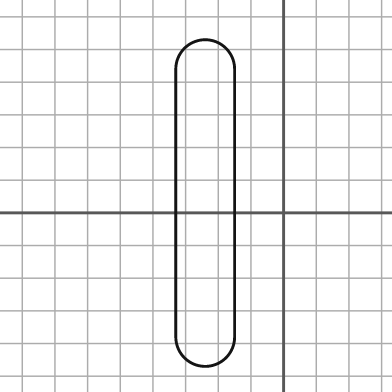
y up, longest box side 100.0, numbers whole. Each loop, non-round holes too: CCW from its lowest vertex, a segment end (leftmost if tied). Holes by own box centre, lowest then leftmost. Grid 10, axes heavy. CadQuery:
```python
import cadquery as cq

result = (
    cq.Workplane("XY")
    .moveTo(-33.0, -38.0)
    .threePointArc((-24.0, -47.0), (-15.0, -38.0))
    .lineTo(-15.0, 44.0)
    .threePointArc((-24.0, 53.0), (-33.0, 44.0))
    .close()
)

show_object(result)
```